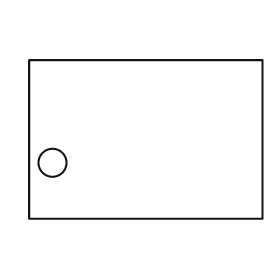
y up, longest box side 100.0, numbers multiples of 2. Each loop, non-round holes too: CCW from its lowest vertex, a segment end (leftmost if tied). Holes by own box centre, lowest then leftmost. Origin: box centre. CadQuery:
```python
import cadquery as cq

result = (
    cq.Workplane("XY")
    .moveTo(-50.0, -34.0)
    .lineTo(50.0, -34.0)
    .lineTo(50.0, 34.0)
    .lineTo(-50.0, 34.0)
    .close()
    .moveTo(-40.0, -10.0)
    .circle(6.0)
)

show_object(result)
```